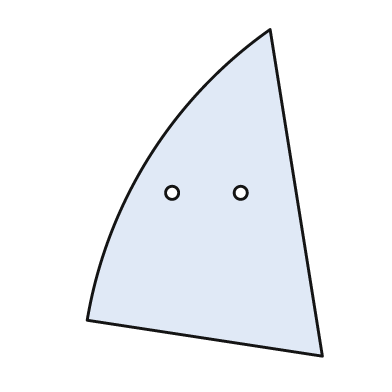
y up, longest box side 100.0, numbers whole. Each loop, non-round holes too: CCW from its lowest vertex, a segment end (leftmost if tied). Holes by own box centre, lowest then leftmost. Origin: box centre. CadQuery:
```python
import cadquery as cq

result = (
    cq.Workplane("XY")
    .moveTo(36.0, -50.0)
    .lineTo(20.0, 50.0)
    .threePointArc((-17.0, 11.0), (-36.0, -39.0))
    .close()
    .moveTo(-10.0, 0.0)
    .circle(2.0)
    .moveTo(11.0, 0.0)
    .circle(2.0)
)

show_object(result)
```